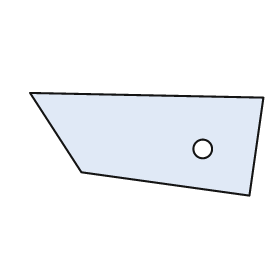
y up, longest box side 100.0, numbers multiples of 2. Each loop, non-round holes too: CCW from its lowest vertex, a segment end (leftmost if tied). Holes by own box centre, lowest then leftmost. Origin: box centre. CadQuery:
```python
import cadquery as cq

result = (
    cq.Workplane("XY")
    .moveTo(44.0, -22.0)
    .lineTo(50.0, 20.0)
    .lineTo(-50.0, 22.0)
    .lineTo(-28.0, -12.0)
    .close()
    .moveTo(24.0, -2.0)
    .circle(4.0)
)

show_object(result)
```